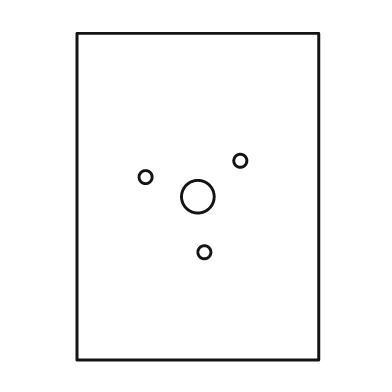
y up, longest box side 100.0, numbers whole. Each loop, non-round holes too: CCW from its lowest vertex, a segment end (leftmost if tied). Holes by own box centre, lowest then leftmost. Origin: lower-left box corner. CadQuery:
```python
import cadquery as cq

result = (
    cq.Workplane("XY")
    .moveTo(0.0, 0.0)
    .lineTo(74.0, 0.0)
    .lineTo(74.0, 100.0)
    .lineTo(0.0, 100.0)
    .close()
    .moveTo(39.0, 33.0)
    .circle(2.0)
    .moveTo(37.0, 50.0)
    .circle(5.0)
    .moveTo(21.0, 56.0)
    .circle(2.0)
    .moveTo(50.0, 61.0)
    .circle(2.0)
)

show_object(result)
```